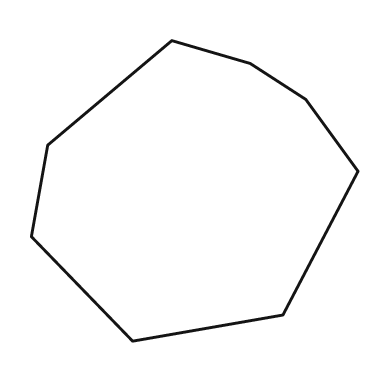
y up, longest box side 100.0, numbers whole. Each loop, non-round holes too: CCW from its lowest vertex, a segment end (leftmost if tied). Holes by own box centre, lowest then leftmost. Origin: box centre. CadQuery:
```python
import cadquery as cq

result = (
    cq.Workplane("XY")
    .moveTo(-19.0, -46.0)
    .lineTo(27.0, -38.0)
    .lineTo(50.0, 6.0)
    .lineTo(34.0, 28.0)
    .lineTo(17.0, 39.0)
    .lineTo(-7.0, 46.0)
    .lineTo(-45.0, 14.0)
    .lineTo(-50.0, -14.0)
    .close()
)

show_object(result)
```